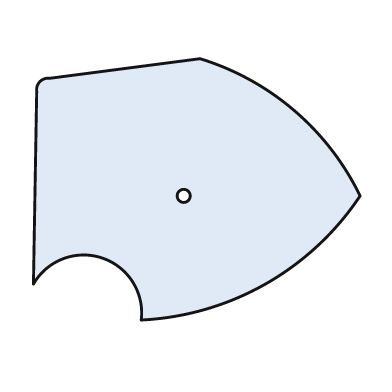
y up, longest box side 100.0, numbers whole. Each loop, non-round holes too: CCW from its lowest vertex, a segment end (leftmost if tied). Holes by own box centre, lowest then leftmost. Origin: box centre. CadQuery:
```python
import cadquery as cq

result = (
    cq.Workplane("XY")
    .moveTo(-17.0, -40.0)
    .threePointArc((21.0, -29.0), (50.0, -2.0))
    .threePointArc((30.0, 24.0), (1.0, 40.0))
    .lineTo(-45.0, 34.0)
    .threePointArc((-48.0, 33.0), (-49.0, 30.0))
    .lineTo(-50.0, -29.0)
    .threePointArc((-29.0, -21.0), (-17.0, -40.0))
    .close()
    .moveTo(-4.0, -2.0)
    .circle(2.0)
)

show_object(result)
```